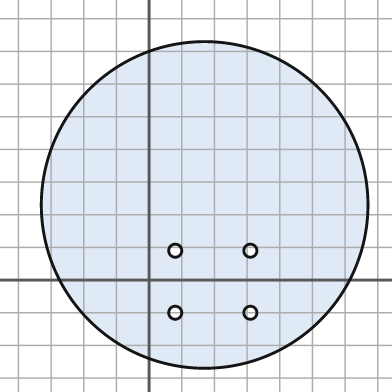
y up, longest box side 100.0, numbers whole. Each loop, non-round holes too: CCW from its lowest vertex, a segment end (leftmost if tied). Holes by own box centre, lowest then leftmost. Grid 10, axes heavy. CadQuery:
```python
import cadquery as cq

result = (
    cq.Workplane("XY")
    .moveTo(17.0, 23.0)
    .circle(50.0)
    .moveTo(8.0, -10.0)
    .circle(2.0)
    .moveTo(31.0, -10.0)
    .circle(2.0)
    .moveTo(8.0, 9.0)
    .circle(2.0)
    .moveTo(31.0, 9.0)
    .circle(2.0)
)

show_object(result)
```